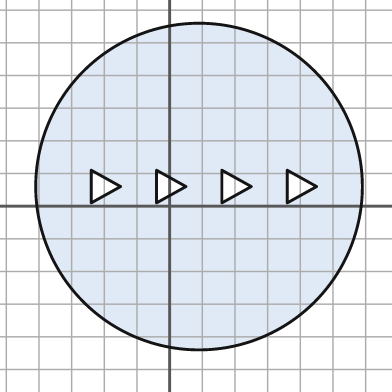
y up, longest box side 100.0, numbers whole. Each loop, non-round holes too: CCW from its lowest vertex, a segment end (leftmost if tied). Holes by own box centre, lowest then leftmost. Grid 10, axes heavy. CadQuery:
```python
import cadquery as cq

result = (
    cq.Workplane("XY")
    .moveTo(9.0, 6.0)
    .circle(50.0)
    .moveTo(-24.0, 1.0)
    .lineTo(-15.0, 6.0)
    .lineTo(-24.0, 11.0)
    .close()
    .moveTo(-4.0, 1.0)
    .lineTo(5.0, 6.0)
    .lineTo(-4.0, 11.0)
    .close()
    .moveTo(16.0, 1.0)
    .lineTo(25.0, 6.0)
    .lineTo(16.0, 11.0)
    .close()
    .moveTo(36.0, 1.0)
    .lineTo(45.0, 6.0)
    .lineTo(36.0, 11.0)
    .close()
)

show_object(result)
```